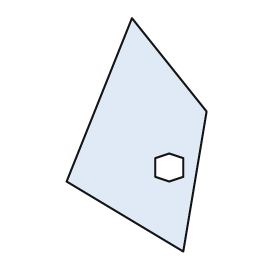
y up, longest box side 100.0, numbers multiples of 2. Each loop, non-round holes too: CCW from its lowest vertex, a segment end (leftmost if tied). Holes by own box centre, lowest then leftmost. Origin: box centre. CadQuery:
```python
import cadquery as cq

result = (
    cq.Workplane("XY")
    .moveTo(20.0, -50.0)
    .lineTo(30.0, 10.0)
    .lineTo(-2.0, 50.0)
    .lineTo(-30.0, -20.0)
    .close()
    .moveTo(14.0, -20.0)
    .lineTo(20.0, -18.0)
    .lineTo(20.0, -10.0)
    .lineTo(14.0, -8.0)
    .lineTo(8.0, -10.0)
    .lineTo(8.0, -18.0)
    .close()
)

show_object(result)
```